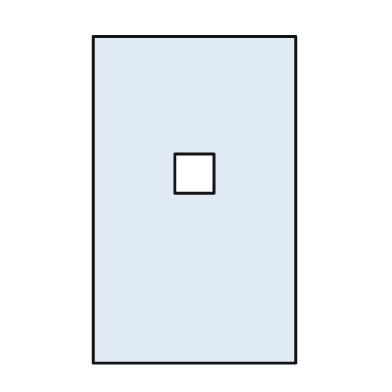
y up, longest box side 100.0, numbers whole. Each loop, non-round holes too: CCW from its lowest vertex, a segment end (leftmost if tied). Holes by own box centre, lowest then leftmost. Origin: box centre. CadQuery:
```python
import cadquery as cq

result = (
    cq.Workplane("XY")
    .moveTo(-31.0, -50.0)
    .lineTo(31.0, -50.0)
    .lineTo(31.0, 50.0)
    .lineTo(-31.0, 50.0)
    .close()
    .moveTo(-6.0, 2.0)
    .lineTo(6.0, 2.0)
    .lineTo(6.0, 14.0)
    .lineTo(-6.0, 14.0)
    .close()
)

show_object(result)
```